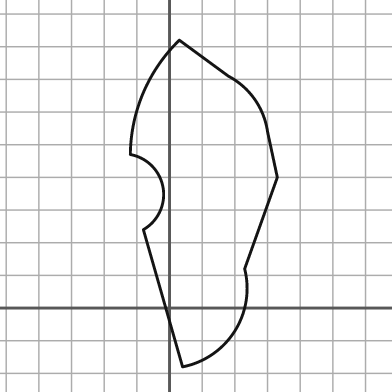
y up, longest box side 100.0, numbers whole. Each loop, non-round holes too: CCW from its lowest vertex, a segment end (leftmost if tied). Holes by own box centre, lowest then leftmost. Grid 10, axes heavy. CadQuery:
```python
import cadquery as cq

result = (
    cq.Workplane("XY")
    .moveTo(4.0, -18.0)
    .threePointArc((20.0, -7.0), (23.0, 12.0))
    .lineTo(33.0, 40.0)
    .lineTo(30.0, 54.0)
    .threePointArc((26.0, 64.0), (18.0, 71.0))
    .lineTo(3.0, 82.0)
    .threePointArc((-8.0, 66.0), (-12.0, 47.0))
    .threePointArc((-2.0, 37.0), (-8.0, 24.0))
    .close()
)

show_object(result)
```